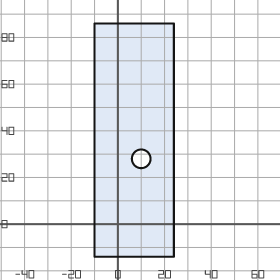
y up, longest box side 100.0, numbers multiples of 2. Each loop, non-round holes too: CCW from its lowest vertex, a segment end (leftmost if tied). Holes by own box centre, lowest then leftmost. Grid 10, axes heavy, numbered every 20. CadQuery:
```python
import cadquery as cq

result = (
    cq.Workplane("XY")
    .moveTo(-10.0, -14.0)
    .lineTo(24.0, -14.0)
    .lineTo(24.0, 86.0)
    .lineTo(-10.0, 86.0)
    .close()
    .moveTo(10.0, 28.0)
    .circle(4.0)
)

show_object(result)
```